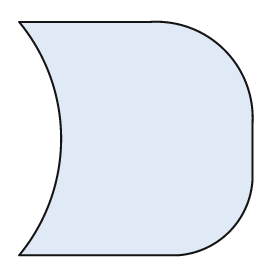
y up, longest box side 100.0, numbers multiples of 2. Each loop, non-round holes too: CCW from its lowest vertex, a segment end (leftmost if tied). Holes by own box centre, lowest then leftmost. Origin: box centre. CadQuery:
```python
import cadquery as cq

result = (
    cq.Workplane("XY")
    .moveTo(-50.0, -50.0)
    .lineTo(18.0, -50.0)
    .threePointArc((40.0, -40.0), (50.0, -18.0))
    .lineTo(50.0, 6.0)
    .threePointArc((38.0, 38.0), (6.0, 50.0))
    .lineTo(-50.0, 50.0)
    .threePointArc((-32.0, 0.0), (-50.0, -50.0))
    .close()
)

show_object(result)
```